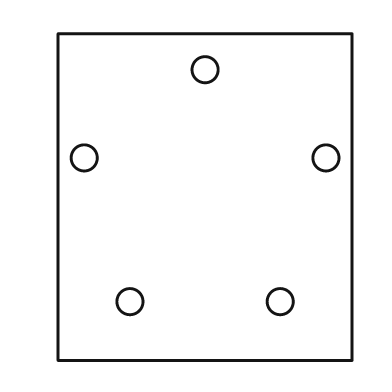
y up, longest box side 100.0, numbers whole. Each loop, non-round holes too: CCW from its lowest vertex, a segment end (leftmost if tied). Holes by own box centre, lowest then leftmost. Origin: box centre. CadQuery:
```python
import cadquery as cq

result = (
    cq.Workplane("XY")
    .moveTo(-45.0, -50.0)
    .lineTo(45.0, -50.0)
    .lineTo(45.0, 50.0)
    .lineTo(-45.0, 50.0)
    .close()
    .moveTo(-23.0, -32.0)
    .circle(4.0)
    .moveTo(23.0, -32.0)
    .circle(4.0)
    .moveTo(-37.0, 12.0)
    .circle(4.0)
    .moveTo(37.0, 12.0)
    .circle(4.0)
    .moveTo(0.0, 39.0)
    .circle(4.0)
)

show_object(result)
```